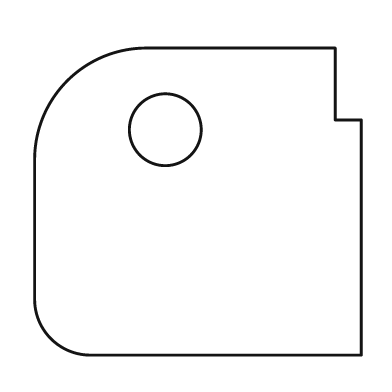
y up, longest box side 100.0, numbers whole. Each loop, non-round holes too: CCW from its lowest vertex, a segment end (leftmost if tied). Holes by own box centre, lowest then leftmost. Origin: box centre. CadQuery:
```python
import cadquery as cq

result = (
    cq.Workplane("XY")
    .moveTo(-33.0, -47.0)
    .lineTo(50.0, -47.0)
    .lineTo(50.0, 25.0)
    .lineTo(42.0, 25.0)
    .lineTo(42.0, 47.0)
    .lineTo(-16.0, 47.0)
    .threePointArc((-40.0, 37.0), (-50.0, 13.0))
    .lineTo(-50.0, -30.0)
    .threePointArc((-45.0, -42.0), (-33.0, -47.0))
    .close()
    .moveTo(-10.0, 22.0)
    .circle(11.0)
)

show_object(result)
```